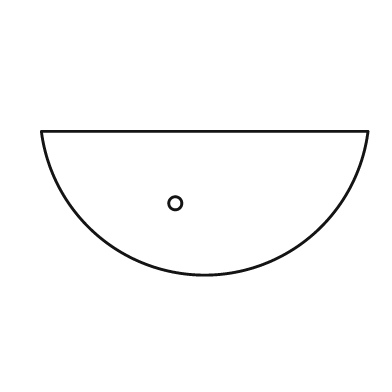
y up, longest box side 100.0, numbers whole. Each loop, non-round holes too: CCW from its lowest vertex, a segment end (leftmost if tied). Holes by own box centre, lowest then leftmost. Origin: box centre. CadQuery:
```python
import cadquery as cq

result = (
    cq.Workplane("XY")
    .moveTo(-50.0, 22.0)
    .threePointArc((0.0, -22.0), (50.0, 22.0))
    .close()
    .moveTo(-9.0, 0.0)
    .circle(2.0)
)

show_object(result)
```